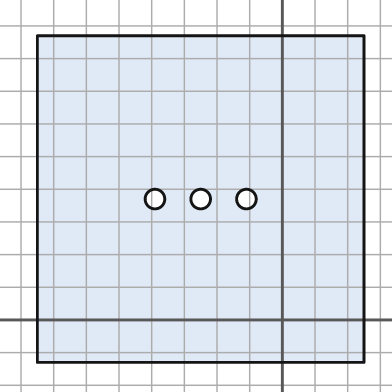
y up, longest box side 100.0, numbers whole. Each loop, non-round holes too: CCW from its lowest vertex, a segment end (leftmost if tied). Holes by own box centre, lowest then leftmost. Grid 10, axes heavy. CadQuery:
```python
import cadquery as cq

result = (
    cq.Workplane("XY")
    .moveTo(-75.0, -13.0)
    .lineTo(25.0, -13.0)
    .lineTo(25.0, 87.0)
    .lineTo(-75.0, 87.0)
    .close()
    .moveTo(-39.0, 37.0)
    .circle(3.0)
    .moveTo(-25.0, 37.0)
    .circle(3.0)
    .moveTo(-11.0, 37.0)
    .circle(3.0)
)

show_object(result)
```